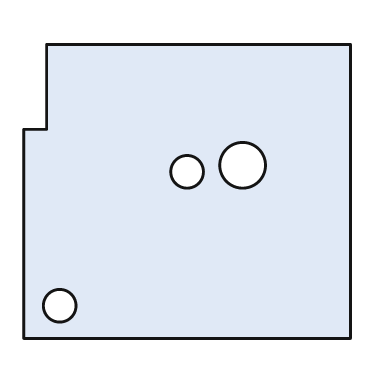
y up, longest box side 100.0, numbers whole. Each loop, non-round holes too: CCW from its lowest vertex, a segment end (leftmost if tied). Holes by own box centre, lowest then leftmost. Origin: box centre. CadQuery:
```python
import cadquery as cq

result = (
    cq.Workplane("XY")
    .moveTo(-50.0, -45.0)
    .lineTo(50.0, -45.0)
    .lineTo(50.0, 45.0)
    .lineTo(-43.0, 45.0)
    .lineTo(-43.0, 19.0)
    .lineTo(-50.0, 19.0)
    .close()
    .moveTo(-39.0, -35.0)
    .circle(5.0)
    .moveTo(0.0, 6.0)
    .circle(5.0)
    .moveTo(17.0, 8.0)
    .circle(7.0)
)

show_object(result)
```